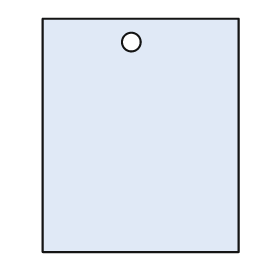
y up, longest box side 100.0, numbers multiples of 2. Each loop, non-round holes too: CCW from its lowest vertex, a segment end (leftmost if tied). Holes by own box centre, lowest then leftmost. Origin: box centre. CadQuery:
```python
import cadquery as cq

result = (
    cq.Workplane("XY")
    .moveTo(-42.0, -50.0)
    .lineTo(42.0, -50.0)
    .lineTo(42.0, 50.0)
    .lineTo(-42.0, 50.0)
    .close()
    .moveTo(-4.0, 40.0)
    .circle(4.0)
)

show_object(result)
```